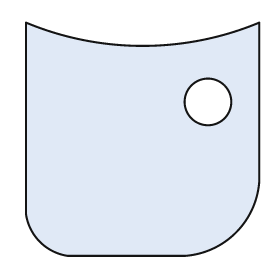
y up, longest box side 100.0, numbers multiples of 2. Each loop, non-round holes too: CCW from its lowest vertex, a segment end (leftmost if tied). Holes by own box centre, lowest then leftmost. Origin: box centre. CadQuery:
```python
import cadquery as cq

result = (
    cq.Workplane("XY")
    .moveTo(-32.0, -50.0)
    .lineTo(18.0, -50.0)
    .threePointArc((40.0, -40.0), (50.0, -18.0))
    .lineTo(50.0, 50.0)
    .threePointArc((0.0, 40.0), (-50.0, 50.0))
    .lineTo(-50.0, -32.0)
    .threePointArc((-44.0, -44.0), (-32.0, -50.0))
    .close()
    .moveTo(28.0, 16.0)
    .circle(10.0)
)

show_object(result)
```